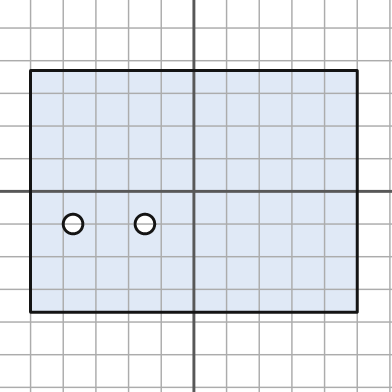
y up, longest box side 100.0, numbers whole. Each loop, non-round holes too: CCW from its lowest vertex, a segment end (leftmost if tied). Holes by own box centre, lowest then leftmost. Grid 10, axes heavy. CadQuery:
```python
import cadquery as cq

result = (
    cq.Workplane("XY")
    .moveTo(-50.0, -37.0)
    .lineTo(50.0, -37.0)
    .lineTo(50.0, 37.0)
    .lineTo(-50.0, 37.0)
    .close()
    .moveTo(-37.0, -10.0)
    .circle(3.0)
    .moveTo(-15.0, -10.0)
    .circle(3.0)
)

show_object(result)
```